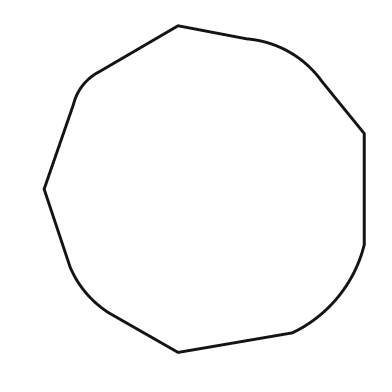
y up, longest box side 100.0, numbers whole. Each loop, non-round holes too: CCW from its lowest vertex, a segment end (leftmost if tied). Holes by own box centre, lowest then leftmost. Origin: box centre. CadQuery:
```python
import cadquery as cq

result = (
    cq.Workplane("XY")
    .moveTo(-8.0, -50.0)
    .lineTo(27.0, -44.0)
    .threePointArc((41.0, -33.0), (49.0, -17.0))
    .lineTo(49.0, 17.0)
    .lineTo(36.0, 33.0)
    .threePointArc((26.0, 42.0), (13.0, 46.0))
    .lineTo(-8.0, 50.0)
    .lineTo(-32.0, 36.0)
    .threePointArc((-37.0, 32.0), (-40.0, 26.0))
    .lineTo(-49.0, 0.0)
    .lineTo(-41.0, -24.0)
    .threePointArc((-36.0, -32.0), (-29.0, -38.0))
    .close()
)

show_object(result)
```